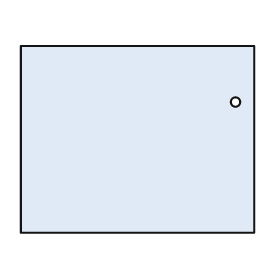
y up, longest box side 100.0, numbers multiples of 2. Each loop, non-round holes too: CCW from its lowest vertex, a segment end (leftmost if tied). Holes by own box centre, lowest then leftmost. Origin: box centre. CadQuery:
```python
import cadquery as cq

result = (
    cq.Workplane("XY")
    .moveTo(-50.0, -40.0)
    .lineTo(50.0, -40.0)
    .lineTo(50.0, 40.0)
    .lineTo(-50.0, 40.0)
    .close()
    .moveTo(42.0, 16.0)
    .circle(2.0)
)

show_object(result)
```